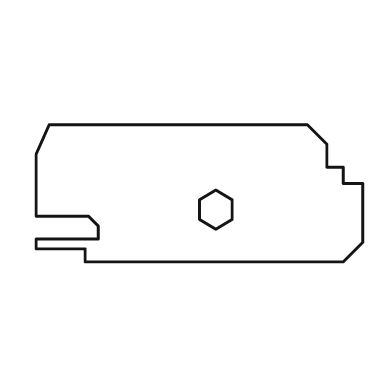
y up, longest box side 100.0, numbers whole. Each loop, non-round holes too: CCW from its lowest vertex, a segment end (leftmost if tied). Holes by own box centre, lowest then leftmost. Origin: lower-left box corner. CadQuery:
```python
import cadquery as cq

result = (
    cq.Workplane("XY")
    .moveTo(15.0, 0.0)
    .lineTo(94.0, 0.0)
    .lineTo(100.0, 6.0)
    .lineTo(100.0, 24.0)
    .lineTo(94.0, 24.0)
    .lineTo(94.0, 29.0)
    .lineTo(89.0, 29.0)
    .lineTo(89.0, 36.0)
    .lineTo(83.0, 42.0)
    .lineTo(4.0, 42.0)
    .lineTo(0.0, 33.0)
    .lineTo(0.0, 14.0)
    .lineTo(16.0, 14.0)
    .lineTo(19.0, 11.0)
    .lineTo(19.0, 7.0)
    .lineTo(0.0, 7.0)
    .lineTo(0.0, 4.0)
    .lineTo(15.0, 4.0)
    .close()
    .moveTo(55.0, 10.0)
    .lineTo(60.0, 13.0)
    .lineTo(60.0, 19.0)
    .lineTo(55.0, 22.0)
    .lineTo(50.0, 19.0)
    .lineTo(50.0, 13.0)
    .close()
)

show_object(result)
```